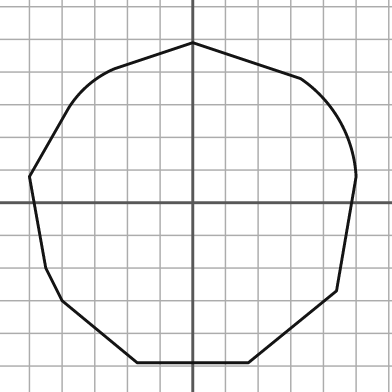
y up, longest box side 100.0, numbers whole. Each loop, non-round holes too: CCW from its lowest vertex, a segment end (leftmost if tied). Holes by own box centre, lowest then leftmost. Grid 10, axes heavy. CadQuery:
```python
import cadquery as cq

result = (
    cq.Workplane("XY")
    .moveTo(-17.0, -49.0)
    .lineTo(17.0, -49.0)
    .lineTo(44.0, -27.0)
    .lineTo(50.0, 8.0)
    .threePointArc((45.0, 25.0), (33.0, 38.0))
    .lineTo(0.0, 49.0)
    .lineTo(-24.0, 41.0)
    .threePointArc((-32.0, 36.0), (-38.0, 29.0))
    .lineTo(-50.0, 8.0)
    .lineTo(-45.0, -20.0)
    .lineTo(-40.0, -30.0)
    .close()
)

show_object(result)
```